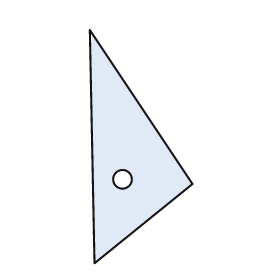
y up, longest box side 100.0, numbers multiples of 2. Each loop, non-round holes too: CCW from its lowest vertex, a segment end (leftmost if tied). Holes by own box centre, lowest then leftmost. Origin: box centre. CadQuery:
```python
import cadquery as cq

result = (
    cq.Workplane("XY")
    .moveTo(-20.0, -50.0)
    .lineTo(22.0, -16.0)
    .lineTo(-22.0, 50.0)
    .close()
    .moveTo(-8.0, -14.0)
    .circle(4.0)
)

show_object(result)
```